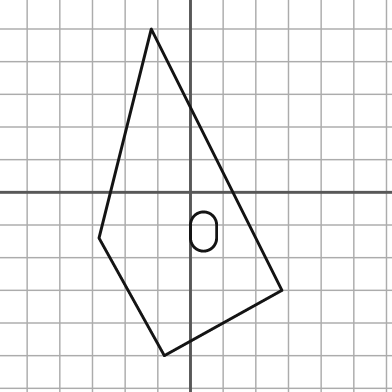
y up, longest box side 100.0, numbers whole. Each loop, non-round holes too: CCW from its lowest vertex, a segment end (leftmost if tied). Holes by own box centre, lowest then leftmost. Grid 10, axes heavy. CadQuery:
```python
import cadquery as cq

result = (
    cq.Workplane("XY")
    .moveTo(-8.0, -50.0)
    .lineTo(28.0, -30.0)
    .lineTo(-12.0, 50.0)
    .lineTo(-28.0, -14.0)
    .close()
    .moveTo(0.0, -14.0)
    .threePointArc((4.0, -18.0), (8.0, -14.0))
    .lineTo(8.0, -10.0)
    .threePointArc((4.0, -6.0), (0.0, -10.0))
    .close()
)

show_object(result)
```